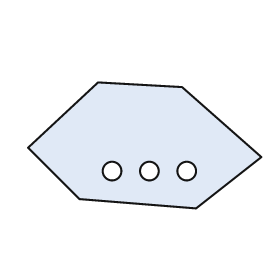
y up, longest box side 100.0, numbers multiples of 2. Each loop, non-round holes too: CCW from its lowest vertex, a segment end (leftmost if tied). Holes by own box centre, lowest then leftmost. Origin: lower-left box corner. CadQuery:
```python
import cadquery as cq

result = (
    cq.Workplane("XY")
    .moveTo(72.0, 0.0)
    .lineTo(100.0, 22.0)
    .lineTo(66.0, 52.0)
    .lineTo(30.0, 54.0)
    .lineTo(0.0, 26.0)
    .lineTo(22.0, 4.0)
    .close()
    .moveTo(36.0, 16.0)
    .circle(4.0)
    .moveTo(52.0, 16.0)
    .circle(4.0)
    .moveTo(68.0, 16.0)
    .circle(4.0)
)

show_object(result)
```